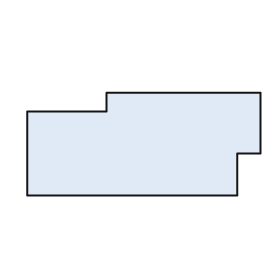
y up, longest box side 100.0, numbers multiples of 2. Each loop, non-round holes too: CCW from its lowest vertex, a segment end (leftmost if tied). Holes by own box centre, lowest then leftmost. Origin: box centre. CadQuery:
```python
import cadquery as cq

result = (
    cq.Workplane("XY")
    .moveTo(-50.0, -22.0)
    .lineTo(40.0, -22.0)
    .lineTo(40.0, -4.0)
    .lineTo(50.0, -4.0)
    .lineTo(50.0, 22.0)
    .lineTo(-16.0, 22.0)
    .lineTo(-16.0, 14.0)
    .lineTo(-50.0, 14.0)
    .close()
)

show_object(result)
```